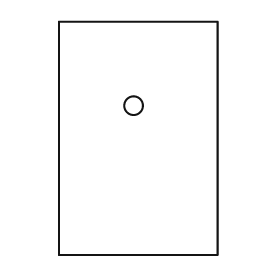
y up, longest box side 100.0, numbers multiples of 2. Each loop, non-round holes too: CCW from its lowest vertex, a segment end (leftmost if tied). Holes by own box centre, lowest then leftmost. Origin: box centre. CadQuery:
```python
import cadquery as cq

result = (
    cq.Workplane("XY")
    .moveTo(-34.0, -50.0)
    .lineTo(34.0, -50.0)
    .lineTo(34.0, 50.0)
    .lineTo(-34.0, 50.0)
    .close()
    .moveTo(-2.0, 14.0)
    .circle(4.0)
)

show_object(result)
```